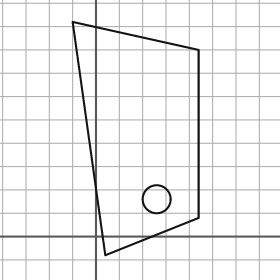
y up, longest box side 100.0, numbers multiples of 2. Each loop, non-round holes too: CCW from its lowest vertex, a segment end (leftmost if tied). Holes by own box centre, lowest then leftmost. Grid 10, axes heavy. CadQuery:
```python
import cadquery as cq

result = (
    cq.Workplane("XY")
    .moveTo(4.0, -8.0)
    .lineTo(44.0, 8.0)
    .lineTo(44.0, 80.0)
    .lineTo(-10.0, 92.0)
    .close()
    .moveTo(26.0, 16.0)
    .circle(6.0)
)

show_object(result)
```